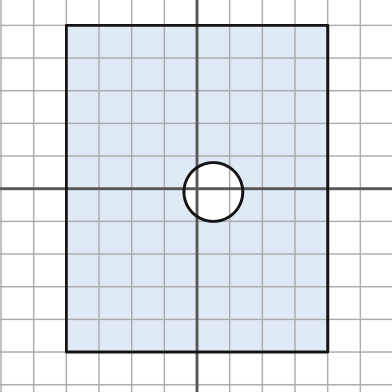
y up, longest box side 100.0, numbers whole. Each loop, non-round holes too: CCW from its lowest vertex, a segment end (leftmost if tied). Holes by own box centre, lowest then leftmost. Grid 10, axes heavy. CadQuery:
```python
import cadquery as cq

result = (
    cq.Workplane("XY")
    .moveTo(-40.0, -50.0)
    .lineTo(40.0, -50.0)
    .lineTo(40.0, 50.0)
    .lineTo(-40.0, 50.0)
    .close()
    .moveTo(5.0, -1.0)
    .circle(9.0)
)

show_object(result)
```